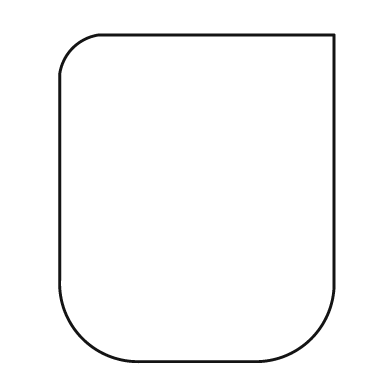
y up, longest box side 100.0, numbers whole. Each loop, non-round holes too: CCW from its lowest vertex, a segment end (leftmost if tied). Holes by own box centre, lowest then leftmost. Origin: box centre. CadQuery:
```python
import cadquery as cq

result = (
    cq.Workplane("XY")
    .moveTo(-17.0, -50.0)
    .lineTo(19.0, -50.0)
    .threePointArc((35.0, -43.0), (42.0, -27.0))
    .lineTo(42.0, 50.0)
    .lineTo(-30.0, 50.0)
    .threePointArc((-38.0, 46.0), (-42.0, 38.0))
    .lineTo(-42.0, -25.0)
    .threePointArc((-35.0, -43.0), (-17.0, -50.0))
    .close()
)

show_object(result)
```